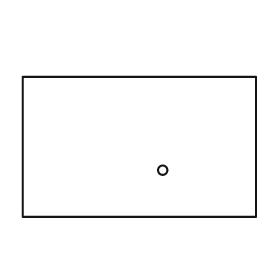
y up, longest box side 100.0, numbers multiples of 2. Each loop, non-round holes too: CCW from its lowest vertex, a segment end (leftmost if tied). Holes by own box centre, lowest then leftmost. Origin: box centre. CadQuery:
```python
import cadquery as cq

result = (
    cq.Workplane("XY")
    .moveTo(-50.0, -30.0)
    .lineTo(50.0, -30.0)
    .lineTo(50.0, 30.0)
    .lineTo(-50.0, 30.0)
    .close()
    .moveTo(10.0, -10.0)
    .circle(2.0)
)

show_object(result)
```